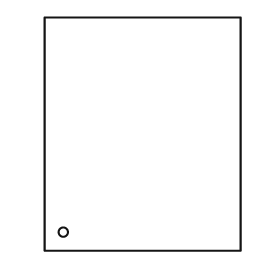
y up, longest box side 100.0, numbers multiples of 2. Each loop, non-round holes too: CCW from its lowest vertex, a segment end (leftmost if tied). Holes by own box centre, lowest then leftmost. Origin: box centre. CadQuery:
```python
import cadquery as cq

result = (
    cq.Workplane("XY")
    .moveTo(-42.0, -50.0)
    .lineTo(42.0, -50.0)
    .lineTo(42.0, 50.0)
    .lineTo(-42.0, 50.0)
    .close()
    .moveTo(-34.0, -42.0)
    .circle(2.0)
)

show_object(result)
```